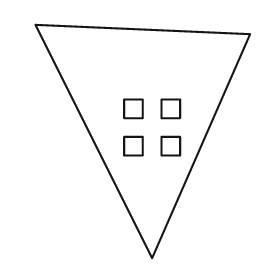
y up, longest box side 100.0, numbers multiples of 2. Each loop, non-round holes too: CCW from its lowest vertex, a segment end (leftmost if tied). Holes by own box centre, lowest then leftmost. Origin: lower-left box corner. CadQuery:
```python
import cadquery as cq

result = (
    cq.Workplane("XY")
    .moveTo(50.0, 0.0)
    .lineTo(92.0, 96.0)
    .lineTo(0.0, 100.0)
    .close()
    .moveTo(38.0, 44.0)
    .lineTo(46.0, 44.0)
    .lineTo(46.0, 52.0)
    .lineTo(38.0, 52.0)
    .close()
    .moveTo(54.0, 44.0)
    .lineTo(62.0, 44.0)
    .lineTo(62.0, 52.0)
    .lineTo(54.0, 52.0)
    .close()
    .moveTo(38.0, 60.0)
    .lineTo(46.0, 60.0)
    .lineTo(46.0, 68.0)
    .lineTo(38.0, 68.0)
    .close()
    .moveTo(54.0, 60.0)
    .lineTo(62.0, 60.0)
    .lineTo(62.0, 68.0)
    .lineTo(54.0, 68.0)
    .close()
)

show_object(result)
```